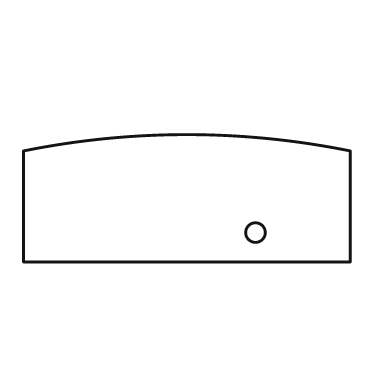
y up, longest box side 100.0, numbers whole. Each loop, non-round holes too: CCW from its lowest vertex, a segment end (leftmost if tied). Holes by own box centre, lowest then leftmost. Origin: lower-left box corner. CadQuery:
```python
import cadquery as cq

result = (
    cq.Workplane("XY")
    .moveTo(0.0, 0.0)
    .lineTo(100.0, 0.0)
    .lineTo(100.0, 34.0)
    .threePointArc((50.0, 39.0), (0.0, 34.0))
    .close()
    .moveTo(71.0, 9.0)
    .circle(3.0)
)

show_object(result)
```